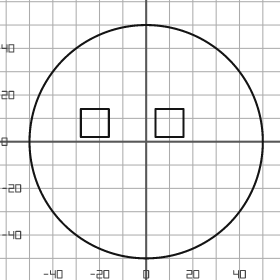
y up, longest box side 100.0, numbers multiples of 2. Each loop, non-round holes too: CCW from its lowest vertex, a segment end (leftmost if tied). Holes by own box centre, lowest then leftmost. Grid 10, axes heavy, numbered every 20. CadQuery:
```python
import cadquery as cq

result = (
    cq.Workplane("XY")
    .moveTo(0.0, 0.0)
    .circle(50.0)
    .moveTo(-28.0, 2.0)
    .lineTo(-16.0, 2.0)
    .lineTo(-16.0, 14.0)
    .lineTo(-28.0, 14.0)
    .close()
    .moveTo(4.0, 2.0)
    .lineTo(16.0, 2.0)
    .lineTo(16.0, 14.0)
    .lineTo(4.0, 14.0)
    .close()
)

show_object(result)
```